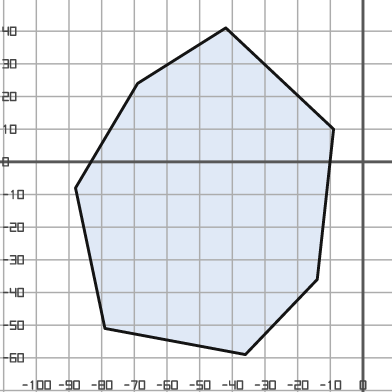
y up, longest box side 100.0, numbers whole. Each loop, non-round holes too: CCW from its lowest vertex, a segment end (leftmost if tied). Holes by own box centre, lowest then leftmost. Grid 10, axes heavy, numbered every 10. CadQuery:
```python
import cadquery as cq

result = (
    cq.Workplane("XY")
    .moveTo(-36.0, -59.0)
    .lineTo(-14.0, -36.0)
    .lineTo(-9.0, 10.0)
    .lineTo(-42.0, 41.0)
    .lineTo(-69.0, 24.0)
    .lineTo(-88.0, -8.0)
    .lineTo(-79.0, -51.0)
    .close()
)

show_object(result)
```